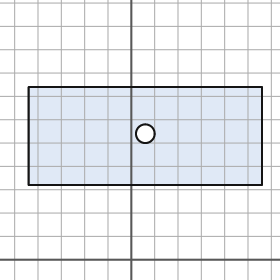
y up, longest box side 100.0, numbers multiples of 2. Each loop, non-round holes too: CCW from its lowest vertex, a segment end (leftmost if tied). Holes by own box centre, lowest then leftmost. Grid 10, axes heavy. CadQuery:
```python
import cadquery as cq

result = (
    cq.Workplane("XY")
    .moveTo(-44.0, 32.0)
    .lineTo(56.0, 32.0)
    .lineTo(56.0, 74.0)
    .lineTo(-44.0, 74.0)
    .close()
    .moveTo(6.0, 54.0)
    .circle(4.0)
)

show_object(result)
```